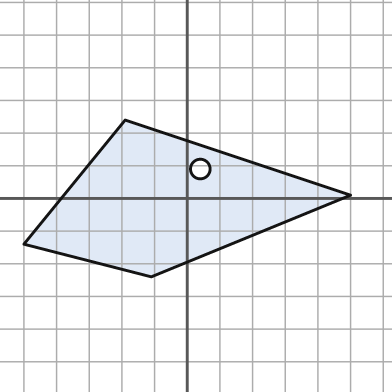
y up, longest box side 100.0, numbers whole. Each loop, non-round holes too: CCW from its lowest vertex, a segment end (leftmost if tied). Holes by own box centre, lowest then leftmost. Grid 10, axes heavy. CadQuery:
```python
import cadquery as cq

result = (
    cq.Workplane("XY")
    .moveTo(-11.0, -24.0)
    .lineTo(50.0, 1.0)
    .lineTo(-19.0, 24.0)
    .lineTo(-50.0, -14.0)
    .close()
    .moveTo(4.0, 9.0)
    .circle(3.0)
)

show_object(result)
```